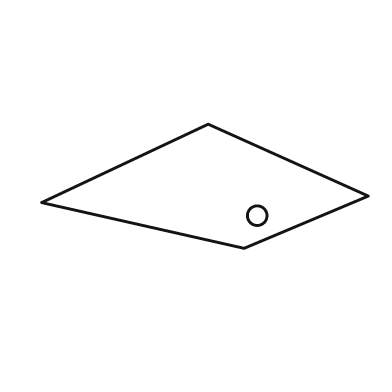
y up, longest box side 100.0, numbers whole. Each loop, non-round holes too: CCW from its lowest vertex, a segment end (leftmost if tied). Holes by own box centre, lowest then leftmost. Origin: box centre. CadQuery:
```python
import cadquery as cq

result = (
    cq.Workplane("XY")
    .moveTo(12.0, -19.0)
    .lineTo(50.0, -3.0)
    .lineTo(1.0, 19.0)
    .lineTo(-50.0, -5.0)
    .close()
    .moveTo(16.0, -9.0)
    .circle(3.0)
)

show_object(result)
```